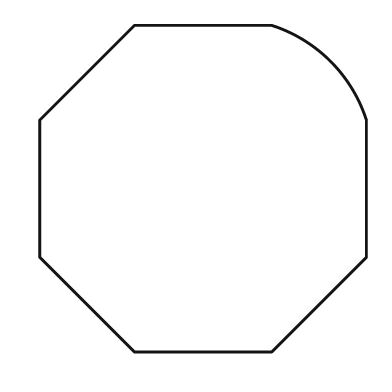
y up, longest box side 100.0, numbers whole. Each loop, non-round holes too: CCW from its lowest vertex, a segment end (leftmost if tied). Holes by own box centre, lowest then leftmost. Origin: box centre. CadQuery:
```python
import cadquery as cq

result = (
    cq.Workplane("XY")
    .moveTo(-21.0, -50.0)
    .lineTo(21.0, -50.0)
    .lineTo(50.0, -21.0)
    .lineTo(50.0, 21.0)
    .threePointArc((39.0, 39.0), (21.0, 50.0))
    .lineTo(-21.0, 50.0)
    .lineTo(-50.0, 21.0)
    .lineTo(-50.0, -21.0)
    .close()
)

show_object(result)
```